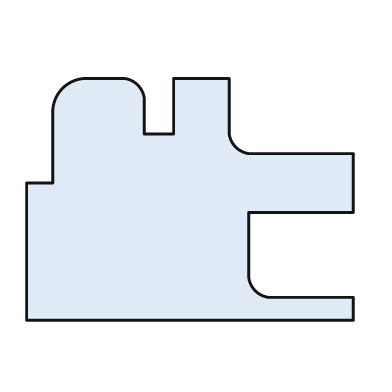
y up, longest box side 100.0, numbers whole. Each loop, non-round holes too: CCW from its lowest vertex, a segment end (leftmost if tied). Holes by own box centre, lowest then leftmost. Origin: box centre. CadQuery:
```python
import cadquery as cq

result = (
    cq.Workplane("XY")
    .moveTo(-50.0, -37.0)
    .lineTo(50.0, -37.0)
    .lineTo(50.0, -30.0)
    .lineTo(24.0, -30.0)
    .threePointArc((20.0, -28.0), (18.0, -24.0))
    .lineTo(18.0, -4.0)
    .lineTo(50.0, -4.0)
    .lineTo(50.0, 14.0)
    .lineTo(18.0, 14.0)
    .threePointArc((14.0, 16.0), (12.0, 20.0))
    .lineTo(12.0, 37.0)
    .lineTo(-5.0, 37.0)
    .lineTo(-5.0, 20.0)
    .lineTo(-14.0, 20.0)
    .lineTo(-14.0, 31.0)
    .threePointArc((-16.0, 35.0), (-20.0, 37.0))
    .lineTo(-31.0, 37.0)
    .threePointArc((-39.0, 34.0), (-42.0, 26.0))
    .lineTo(-42.0, 5.0)
    .lineTo(-50.0, 5.0)
    .close()
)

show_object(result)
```